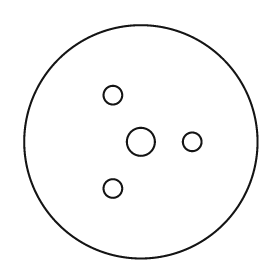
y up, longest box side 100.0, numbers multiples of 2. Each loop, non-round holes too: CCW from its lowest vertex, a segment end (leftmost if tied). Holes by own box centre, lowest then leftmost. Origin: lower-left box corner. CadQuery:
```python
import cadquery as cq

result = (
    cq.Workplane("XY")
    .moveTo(50.0, 50.0)
    .circle(50.0)
    .moveTo(38.0, 30.0)
    .circle(4.0)
    .moveTo(50.0, 50.0)
    .circle(6.0)
    .moveTo(72.0, 50.0)
    .circle(4.0)
    .moveTo(38.0, 70.0)
    .circle(4.0)
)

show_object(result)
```